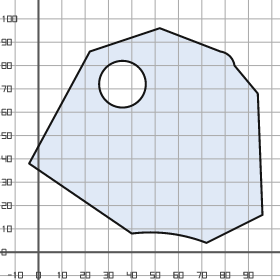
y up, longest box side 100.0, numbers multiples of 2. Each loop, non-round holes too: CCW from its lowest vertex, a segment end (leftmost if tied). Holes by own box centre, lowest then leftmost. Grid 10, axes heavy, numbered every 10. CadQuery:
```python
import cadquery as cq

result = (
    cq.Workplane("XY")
    .moveTo(72.0, 4.0)
    .lineTo(96.0, 16.0)
    .lineTo(94.0, 68.0)
    .lineTo(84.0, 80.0)
    .threePointArc((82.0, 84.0), (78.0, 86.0))
    .lineTo(52.0, 96.0)
    .lineTo(22.0, 86.0)
    .lineTo(-4.0, 38.0)
    .lineTo(40.0, 8.0)
    .threePointArc((56.0, 8.0), (72.0, 4.0))
    .close()
    .moveTo(36.0, 72.0)
    .circle(10.0)
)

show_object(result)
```